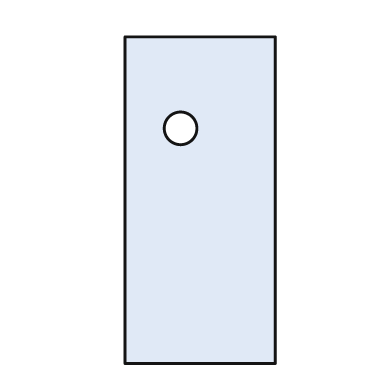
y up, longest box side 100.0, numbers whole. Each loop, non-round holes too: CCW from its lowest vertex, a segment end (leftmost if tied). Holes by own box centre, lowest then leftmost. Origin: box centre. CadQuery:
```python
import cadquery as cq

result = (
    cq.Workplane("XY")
    .moveTo(-23.0, -50.0)
    .lineTo(23.0, -50.0)
    .lineTo(23.0, 50.0)
    .lineTo(-23.0, 50.0)
    .close()
    .moveTo(-6.0, 22.0)
    .circle(5.0)
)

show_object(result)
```